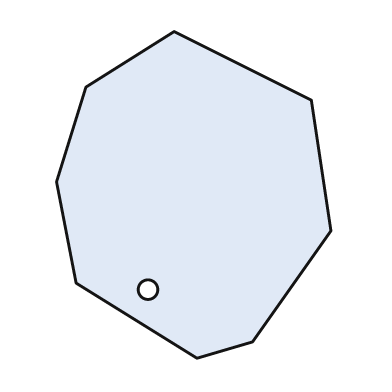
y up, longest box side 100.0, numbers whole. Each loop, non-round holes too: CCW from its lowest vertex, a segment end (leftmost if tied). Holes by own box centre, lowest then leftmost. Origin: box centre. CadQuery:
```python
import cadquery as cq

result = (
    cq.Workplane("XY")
    .moveTo(1.0, -50.0)
    .lineTo(18.0, -45.0)
    .lineTo(42.0, -11.0)
    .lineTo(36.0, 29.0)
    .lineTo(-6.0, 50.0)
    .lineTo(-33.0, 33.0)
    .lineTo(-42.0, 4.0)
    .lineTo(-36.0, -27.0)
    .close()
    .moveTo(-14.0, -29.0)
    .circle(3.0)
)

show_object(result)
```